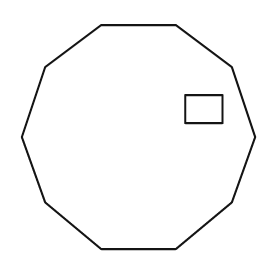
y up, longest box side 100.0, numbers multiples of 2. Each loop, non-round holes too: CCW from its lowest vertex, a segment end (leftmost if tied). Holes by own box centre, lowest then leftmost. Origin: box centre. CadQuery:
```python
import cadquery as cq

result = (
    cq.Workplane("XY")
    .moveTo(-16.0, -48.0)
    .lineTo(16.0, -48.0)
    .lineTo(40.0, -28.0)
    .lineTo(50.0, 0.0)
    .lineTo(40.0, 30.0)
    .lineTo(16.0, 48.0)
    .lineTo(-16.0, 48.0)
    .lineTo(-40.0, 30.0)
    .lineTo(-50.0, 0.0)
    .lineTo(-40.0, -28.0)
    .close()
    .moveTo(20.0, 6.0)
    .lineTo(36.0, 6.0)
    .lineTo(36.0, 18.0)
    .lineTo(20.0, 18.0)
    .close()
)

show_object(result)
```